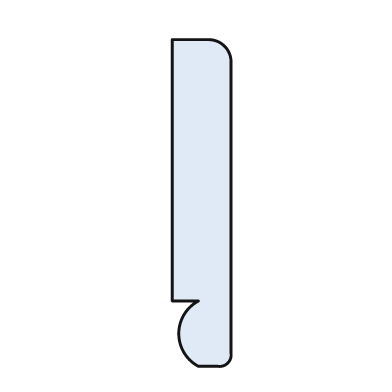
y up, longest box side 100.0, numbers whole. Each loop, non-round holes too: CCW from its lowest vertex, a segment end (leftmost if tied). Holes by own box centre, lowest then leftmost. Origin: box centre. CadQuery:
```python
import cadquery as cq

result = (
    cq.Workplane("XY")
    .moveTo(-1.0, -50.0)
    .lineTo(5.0, -50.0)
    .threePointArc((8.0, -49.0), (9.0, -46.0))
    .lineTo(9.0, 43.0)
    .threePointArc((7.0, 48.0), (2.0, 50.0))
    .lineTo(-9.0, 50.0)
    .lineTo(-9.0, -30.0)
    .lineTo(-1.0, -30.0)
    .threePointArc((-7.0, -40.0), (-1.0, -50.0))
    .close()
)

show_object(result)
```